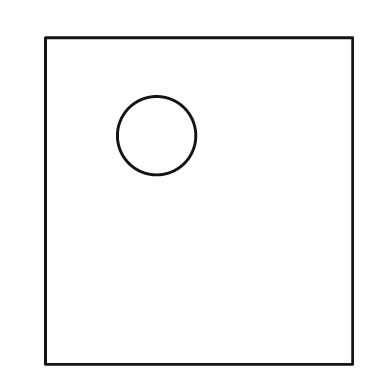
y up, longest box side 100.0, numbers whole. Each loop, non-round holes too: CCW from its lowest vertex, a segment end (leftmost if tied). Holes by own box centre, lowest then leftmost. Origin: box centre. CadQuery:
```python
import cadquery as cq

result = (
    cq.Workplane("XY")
    .moveTo(-47.0, -50.0)
    .lineTo(47.0, -50.0)
    .lineTo(47.0, 50.0)
    .lineTo(-47.0, 50.0)
    .close()
    .moveTo(-13.0, 20.0)
    .circle(12.0)
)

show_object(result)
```